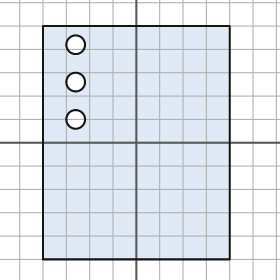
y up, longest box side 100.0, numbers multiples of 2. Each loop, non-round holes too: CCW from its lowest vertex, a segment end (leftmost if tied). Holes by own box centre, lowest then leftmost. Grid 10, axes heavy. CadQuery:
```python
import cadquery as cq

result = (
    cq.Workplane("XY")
    .moveTo(-40.0, -50.0)
    .lineTo(40.0, -50.0)
    .lineTo(40.0, 50.0)
    .lineTo(-40.0, 50.0)
    .close()
    .moveTo(-26.0, 10.0)
    .circle(4.0)
    .moveTo(-26.0, 26.0)
    .circle(4.0)
    .moveTo(-26.0, 42.0)
    .circle(4.0)
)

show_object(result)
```